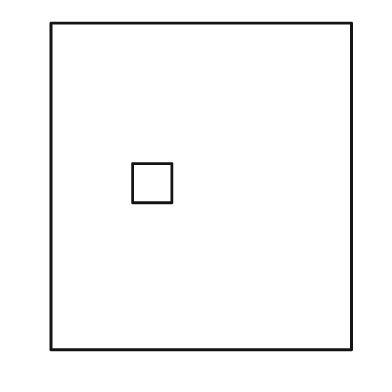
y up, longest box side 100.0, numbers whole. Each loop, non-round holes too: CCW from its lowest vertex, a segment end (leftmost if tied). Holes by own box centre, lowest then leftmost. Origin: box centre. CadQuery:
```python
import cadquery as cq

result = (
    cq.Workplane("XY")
    .moveTo(-46.0, -50.0)
    .lineTo(46.0, -50.0)
    .lineTo(46.0, 50.0)
    .lineTo(-46.0, 50.0)
    .close()
    .moveTo(-21.0, -5.0)
    .lineTo(-9.0, -5.0)
    .lineTo(-9.0, 7.0)
    .lineTo(-21.0, 7.0)
    .close()
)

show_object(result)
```